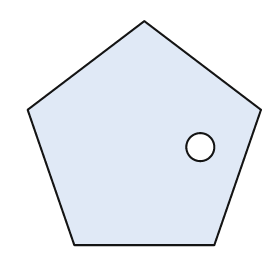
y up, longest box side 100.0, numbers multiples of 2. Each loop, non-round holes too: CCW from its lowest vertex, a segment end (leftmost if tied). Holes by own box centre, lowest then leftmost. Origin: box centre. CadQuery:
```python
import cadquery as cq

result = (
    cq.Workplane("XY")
    .moveTo(-30.0, -48.0)
    .lineTo(30.0, -48.0)
    .lineTo(50.0, 10.0)
    .lineTo(0.0, 48.0)
    .lineTo(-50.0, 10.0)
    .close()
    .moveTo(24.0, -6.0)
    .circle(6.0)
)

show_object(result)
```